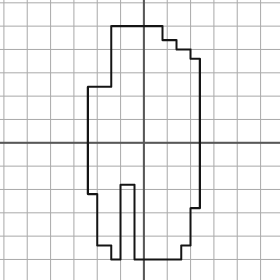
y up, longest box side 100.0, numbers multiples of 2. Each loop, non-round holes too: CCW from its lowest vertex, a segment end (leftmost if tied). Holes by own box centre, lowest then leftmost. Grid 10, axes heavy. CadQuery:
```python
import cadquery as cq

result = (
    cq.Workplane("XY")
    .moveTo(-14.0, -50.0)
    .lineTo(-10.0, -50.0)
    .lineTo(-10.0, -18.0)
    .lineTo(-4.0, -18.0)
    .lineTo(-4.0, -50.0)
    .lineTo(16.0, -50.0)
    .lineTo(16.0, -44.0)
    .lineTo(20.0, -44.0)
    .lineTo(20.0, -28.0)
    .lineTo(24.0, -28.0)
    .lineTo(24.0, 36.0)
    .lineTo(20.0, 36.0)
    .lineTo(20.0, 40.0)
    .lineTo(14.0, 40.0)
    .lineTo(14.0, 44.0)
    .lineTo(8.0, 44.0)
    .lineTo(8.0, 50.0)
    .lineTo(-14.0, 50.0)
    .lineTo(-14.0, 24.0)
    .lineTo(-24.0, 24.0)
    .lineTo(-24.0, -22.0)
    .lineTo(-20.0, -22.0)
    .lineTo(-20.0, -44.0)
    .lineTo(-14.0, -44.0)
    .close()
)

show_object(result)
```